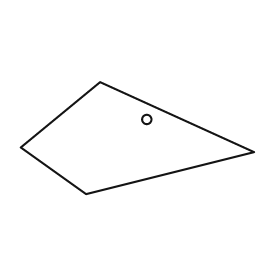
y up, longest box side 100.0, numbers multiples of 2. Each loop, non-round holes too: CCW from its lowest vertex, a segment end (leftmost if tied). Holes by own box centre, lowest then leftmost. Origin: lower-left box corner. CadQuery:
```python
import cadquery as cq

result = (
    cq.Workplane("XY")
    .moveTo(28.0, 0.0)
    .lineTo(100.0, 18.0)
    .lineTo(34.0, 48.0)
    .lineTo(0.0, 20.0)
    .close()
    .moveTo(54.0, 32.0)
    .circle(2.0)
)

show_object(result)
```